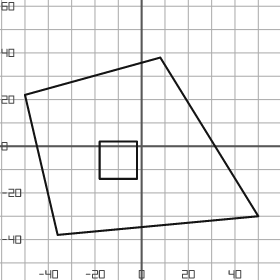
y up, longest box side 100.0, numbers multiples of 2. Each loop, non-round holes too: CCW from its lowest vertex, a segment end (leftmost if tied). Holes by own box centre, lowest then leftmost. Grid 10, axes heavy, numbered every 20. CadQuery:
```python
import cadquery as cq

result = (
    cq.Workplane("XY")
    .moveTo(-36.0, -38.0)
    .lineTo(50.0, -30.0)
    .lineTo(8.0, 38.0)
    .lineTo(-50.0, 22.0)
    .close()
    .moveTo(-18.0, -14.0)
    .lineTo(-2.0, -14.0)
    .lineTo(-2.0, 2.0)
    .lineTo(-18.0, 2.0)
    .close()
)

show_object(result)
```